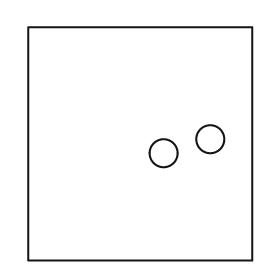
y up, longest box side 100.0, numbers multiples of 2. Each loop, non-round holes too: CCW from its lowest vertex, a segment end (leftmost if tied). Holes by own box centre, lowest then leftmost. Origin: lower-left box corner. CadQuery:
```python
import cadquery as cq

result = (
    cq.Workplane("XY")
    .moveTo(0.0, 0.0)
    .lineTo(96.0, 0.0)
    .lineTo(96.0, 100.0)
    .lineTo(0.0, 100.0)
    .close()
    .moveTo(58.0, 46.0)
    .circle(6.0)
    .moveTo(78.0, 52.0)
    .circle(6.0)
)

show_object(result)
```